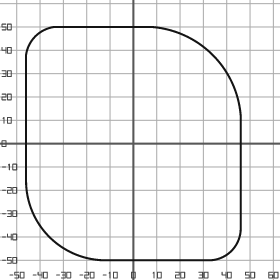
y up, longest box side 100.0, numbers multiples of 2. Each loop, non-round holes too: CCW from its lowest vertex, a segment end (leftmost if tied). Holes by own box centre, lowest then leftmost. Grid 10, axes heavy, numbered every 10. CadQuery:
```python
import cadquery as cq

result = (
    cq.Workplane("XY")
    .moveTo(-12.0, -50.0)
    .lineTo(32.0, -50.0)
    .threePointArc((42.0, -46.0), (46.0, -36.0))
    .lineTo(46.0, 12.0)
    .threePointArc((34.0, 38.0), (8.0, 50.0))
    .lineTo(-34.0, 50.0)
    .threePointArc((-42.0, 46.0), (-46.0, 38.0))
    .lineTo(-46.0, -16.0)
    .threePointArc((-36.0, -40.0), (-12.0, -50.0))
    .close()
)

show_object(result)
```